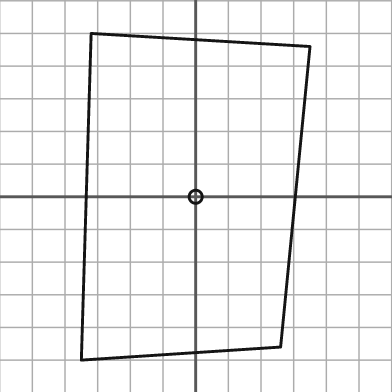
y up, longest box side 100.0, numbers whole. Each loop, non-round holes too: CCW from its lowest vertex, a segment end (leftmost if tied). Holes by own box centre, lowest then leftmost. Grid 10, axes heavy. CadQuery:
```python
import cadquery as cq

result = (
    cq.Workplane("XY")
    .moveTo(-35.0, -50.0)
    .lineTo(26.0, -46.0)
    .lineTo(35.0, 46.0)
    .lineTo(-32.0, 50.0)
    .close()
    .moveTo(0.0, 0.0)
    .circle(2.0)
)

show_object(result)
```